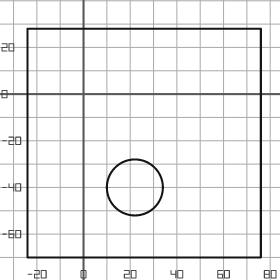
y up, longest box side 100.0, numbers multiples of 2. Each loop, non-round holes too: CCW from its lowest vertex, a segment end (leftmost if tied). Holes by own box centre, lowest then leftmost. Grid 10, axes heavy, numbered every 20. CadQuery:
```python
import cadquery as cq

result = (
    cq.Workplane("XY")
    .moveTo(-24.0, -70.0)
    .lineTo(76.0, -70.0)
    .lineTo(76.0, 28.0)
    .lineTo(-24.0, 28.0)
    .close()
    .moveTo(22.0, -40.0)
    .circle(12.0)
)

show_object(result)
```